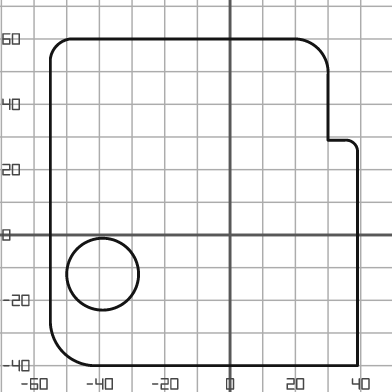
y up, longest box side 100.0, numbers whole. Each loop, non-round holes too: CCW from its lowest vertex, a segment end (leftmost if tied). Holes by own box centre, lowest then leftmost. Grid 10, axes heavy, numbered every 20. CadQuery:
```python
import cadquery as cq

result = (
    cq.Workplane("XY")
    .moveTo(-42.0, -40.0)
    .lineTo(39.0, -40.0)
    .lineTo(39.0, 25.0)
    .threePointArc((38.0, 28.0), (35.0, 29.0))
    .lineTo(30.0, 29.0)
    .lineTo(30.0, 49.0)
    .threePointArc((27.0, 57.0), (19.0, 60.0))
    .lineTo(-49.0, 60.0)
    .threePointArc((-53.0, 58.0), (-55.0, 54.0))
    .lineTo(-55.0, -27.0)
    .threePointArc((-51.0, -36.0), (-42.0, -40.0))
    .close()
    .moveTo(-39.0, -12.0)
    .circle(11.0)
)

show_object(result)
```